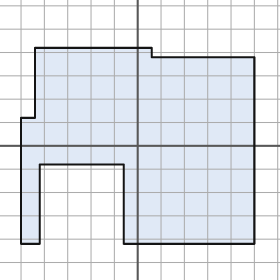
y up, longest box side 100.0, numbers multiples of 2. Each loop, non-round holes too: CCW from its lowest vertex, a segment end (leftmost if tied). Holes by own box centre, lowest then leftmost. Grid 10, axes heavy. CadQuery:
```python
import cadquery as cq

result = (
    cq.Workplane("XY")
    .moveTo(-50.0, -42.0)
    .lineTo(-42.0, -42.0)
    .lineTo(-42.0, -8.0)
    .lineTo(-6.0, -8.0)
    .lineTo(-6.0, -42.0)
    .lineTo(50.0, -42.0)
    .lineTo(50.0, 38.0)
    .lineTo(6.0, 38.0)
    .lineTo(6.0, 42.0)
    .lineTo(-44.0, 42.0)
    .lineTo(-44.0, 12.0)
    .lineTo(-50.0, 12.0)
    .close()
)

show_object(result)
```